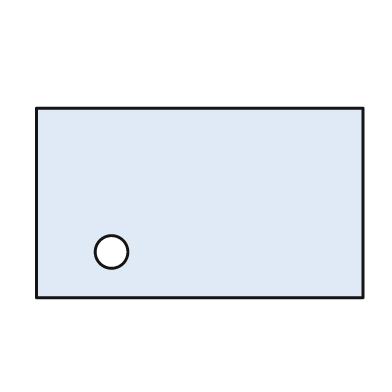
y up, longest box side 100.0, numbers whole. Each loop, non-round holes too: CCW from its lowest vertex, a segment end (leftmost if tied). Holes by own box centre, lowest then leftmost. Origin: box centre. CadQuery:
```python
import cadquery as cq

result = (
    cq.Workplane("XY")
    .moveTo(-50.0, -29.0)
    .lineTo(50.0, -29.0)
    .lineTo(50.0, 29.0)
    .lineTo(-50.0, 29.0)
    .close()
    .moveTo(-27.0, -15.0)
    .circle(5.0)
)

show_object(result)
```